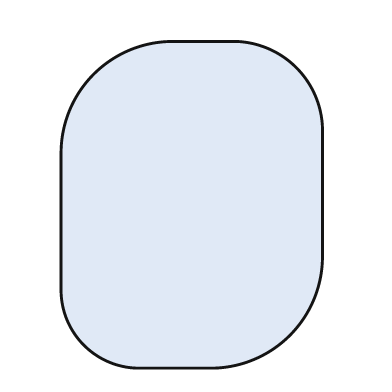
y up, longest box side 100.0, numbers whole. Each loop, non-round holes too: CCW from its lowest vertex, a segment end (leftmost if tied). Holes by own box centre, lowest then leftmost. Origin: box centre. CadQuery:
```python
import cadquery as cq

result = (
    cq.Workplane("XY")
    .moveTo(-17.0, -50.0)
    .lineTo(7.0, -50.0)
    .threePointArc((30.0, -40.0), (40.0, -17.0))
    .lineTo(40.0, 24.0)
    .threePointArc((32.0, 42.0), (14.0, 50.0))
    .lineTo(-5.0, 50.0)
    .threePointArc((-30.0, 40.0), (-40.0, 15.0))
    .lineTo(-40.0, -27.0)
    .threePointArc((-33.0, -43.0), (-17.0, -50.0))
    .close()
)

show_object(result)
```